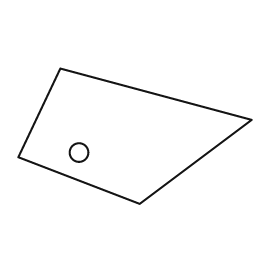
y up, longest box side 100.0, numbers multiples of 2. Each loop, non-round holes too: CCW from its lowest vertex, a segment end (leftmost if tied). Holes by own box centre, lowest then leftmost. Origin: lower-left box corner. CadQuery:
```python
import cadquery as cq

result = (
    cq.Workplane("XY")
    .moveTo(52.0, 0.0)
    .lineTo(100.0, 36.0)
    .lineTo(18.0, 58.0)
    .lineTo(0.0, 20.0)
    .close()
    .moveTo(26.0, 22.0)
    .circle(4.0)
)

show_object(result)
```